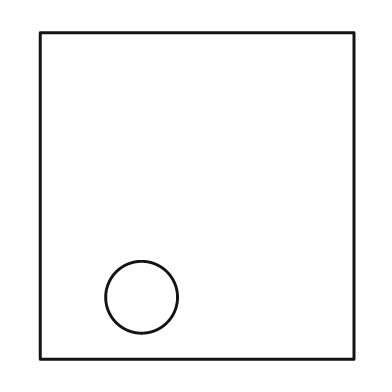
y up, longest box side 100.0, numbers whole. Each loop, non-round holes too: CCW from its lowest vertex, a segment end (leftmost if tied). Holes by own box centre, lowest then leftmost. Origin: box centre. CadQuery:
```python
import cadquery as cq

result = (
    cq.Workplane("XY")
    .moveTo(-48.0, -50.0)
    .lineTo(48.0, -50.0)
    .lineTo(48.0, 50.0)
    .lineTo(-48.0, 50.0)
    .close()
    .moveTo(-17.0, -31.0)
    .circle(11.0)
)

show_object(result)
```